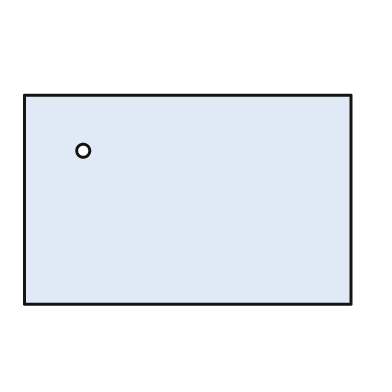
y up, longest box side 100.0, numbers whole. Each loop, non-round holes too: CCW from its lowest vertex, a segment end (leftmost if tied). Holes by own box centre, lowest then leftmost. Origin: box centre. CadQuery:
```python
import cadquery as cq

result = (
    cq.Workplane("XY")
    .moveTo(-50.0, -32.0)
    .lineTo(50.0, -32.0)
    .lineTo(50.0, 32.0)
    .lineTo(-50.0, 32.0)
    .close()
    .moveTo(-32.0, 15.0)
    .circle(2.0)
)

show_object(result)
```